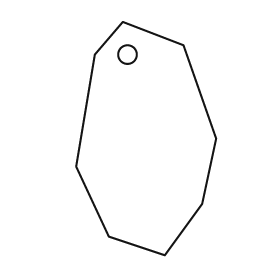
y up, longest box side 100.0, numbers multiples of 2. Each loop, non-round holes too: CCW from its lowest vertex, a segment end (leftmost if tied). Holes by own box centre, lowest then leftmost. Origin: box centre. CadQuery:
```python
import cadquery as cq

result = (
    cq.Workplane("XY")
    .moveTo(8.0, -50.0)
    .lineTo(24.0, -28.0)
    .lineTo(30.0, 0.0)
    .lineTo(16.0, 40.0)
    .lineTo(-10.0, 50.0)
    .lineTo(-22.0, 36.0)
    .lineTo(-30.0, -12.0)
    .lineTo(-16.0, -42.0)
    .close()
    .moveTo(-8.0, 36.0)
    .circle(4.0)
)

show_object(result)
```